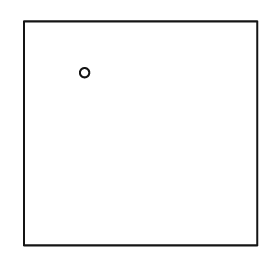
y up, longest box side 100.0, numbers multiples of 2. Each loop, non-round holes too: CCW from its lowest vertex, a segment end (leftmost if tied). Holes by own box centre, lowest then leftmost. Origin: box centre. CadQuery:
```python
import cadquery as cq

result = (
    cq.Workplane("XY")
    .moveTo(-50.0, -48.0)
    .lineTo(50.0, -48.0)
    .lineTo(50.0, 48.0)
    .lineTo(-50.0, 48.0)
    .close()
    .moveTo(-24.0, 26.0)
    .circle(2.0)
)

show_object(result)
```